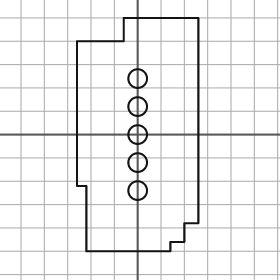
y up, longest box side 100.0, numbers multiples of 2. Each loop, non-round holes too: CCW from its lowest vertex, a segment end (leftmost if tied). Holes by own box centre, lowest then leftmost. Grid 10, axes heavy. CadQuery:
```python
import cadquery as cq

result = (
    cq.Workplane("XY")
    .moveTo(-22.0, -50.0)
    .lineTo(14.0, -50.0)
    .lineTo(14.0, -46.0)
    .lineTo(20.0, -46.0)
    .lineTo(20.0, -38.0)
    .lineTo(26.0, -38.0)
    .lineTo(26.0, 50.0)
    .lineTo(-6.0, 50.0)
    .lineTo(-6.0, 40.0)
    .lineTo(-26.0, 40.0)
    .lineTo(-26.0, -22.0)
    .lineTo(-22.0, -22.0)
    .close()
    .moveTo(0.0, -24.0)
    .circle(4.0)
    .moveTo(0.0, -12.0)
    .circle(4.0)
    .moveTo(0.0, 0.0)
    .circle(4.0)
    .moveTo(0.0, 12.0)
    .circle(4.0)
    .moveTo(0.0, 24.0)
    .circle(4.0)
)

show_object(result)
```